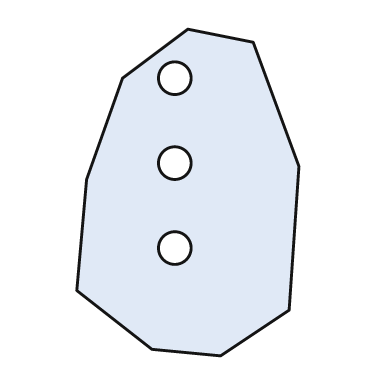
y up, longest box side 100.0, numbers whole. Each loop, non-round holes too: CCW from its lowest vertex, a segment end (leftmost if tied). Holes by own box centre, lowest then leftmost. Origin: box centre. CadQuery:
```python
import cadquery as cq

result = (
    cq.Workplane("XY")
    .moveTo(10.0, -50.0)
    .lineTo(31.0, -36.0)
    .lineTo(34.0, 8.0)
    .lineTo(20.0, 46.0)
    .lineTo(0.0, 50.0)
    .lineTo(-20.0, 35.0)
    .lineTo(-31.0, 4.0)
    .lineTo(-34.0, -30.0)
    .lineTo(-11.0, -48.0)
    .close()
    .moveTo(-4.0, -17.0)
    .circle(5.0)
    .moveTo(-4.0, 9.0)
    .circle(5.0)
    .moveTo(-4.0, 35.0)
    .circle(5.0)
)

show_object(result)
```